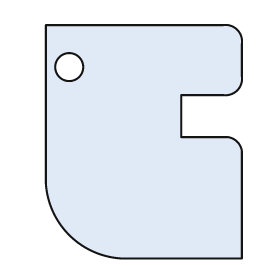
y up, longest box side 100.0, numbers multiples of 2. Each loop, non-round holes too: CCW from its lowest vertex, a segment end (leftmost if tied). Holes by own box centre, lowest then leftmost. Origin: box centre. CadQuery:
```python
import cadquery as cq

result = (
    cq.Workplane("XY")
    .moveTo(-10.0, -50.0)
    .lineTo(42.0, -50.0)
    .lineTo(42.0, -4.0)
    .threePointArc((40.0, 0.0), (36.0, 2.0))
    .lineTo(16.0, 2.0)
    .lineTo(16.0, 20.0)
    .lineTo(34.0, 20.0)
    .threePointArc((40.0, 22.0), (42.0, 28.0))
    .lineTo(42.0, 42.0)
    .threePointArc((40.0, 48.0), (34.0, 50.0))
    .lineTo(-42.0, 50.0)
    .lineTo(-42.0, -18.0)
    .threePointArc((-32.0, -40.0), (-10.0, -50.0))
    .close()
    .moveTo(-32.0, 32.0)
    .circle(6.0)
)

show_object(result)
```